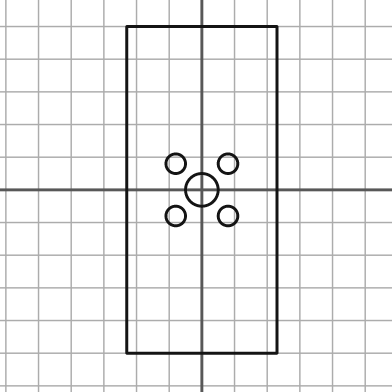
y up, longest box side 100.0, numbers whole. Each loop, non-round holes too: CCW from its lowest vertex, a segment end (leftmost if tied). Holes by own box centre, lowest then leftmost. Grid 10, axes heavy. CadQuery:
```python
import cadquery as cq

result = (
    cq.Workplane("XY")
    .moveTo(-23.0, -50.0)
    .lineTo(23.0, -50.0)
    .lineTo(23.0, 50.0)
    .lineTo(-23.0, 50.0)
    .close()
    .moveTo(-8.0, -8.0)
    .circle(3.0)
    .moveTo(8.0, -8.0)
    .circle(3.0)
    .moveTo(0.0, 0.0)
    .circle(5.0)
    .moveTo(-8.0, 8.0)
    .circle(3.0)
    .moveTo(8.0, 8.0)
    .circle(3.0)
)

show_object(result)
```